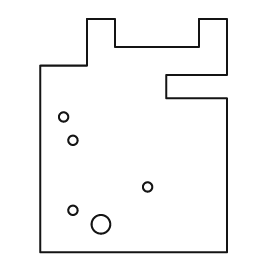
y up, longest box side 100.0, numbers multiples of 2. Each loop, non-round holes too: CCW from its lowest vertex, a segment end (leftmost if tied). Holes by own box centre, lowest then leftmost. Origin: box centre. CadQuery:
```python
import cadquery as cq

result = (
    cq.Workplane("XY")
    .moveTo(-40.0, -50.0)
    .lineTo(40.0, -50.0)
    .lineTo(40.0, 16.0)
    .lineTo(14.0, 16.0)
    .lineTo(14.0, 26.0)
    .lineTo(40.0, 26.0)
    .lineTo(40.0, 50.0)
    .lineTo(28.0, 50.0)
    .lineTo(28.0, 38.0)
    .lineTo(-8.0, 38.0)
    .lineTo(-8.0, 50.0)
    .lineTo(-20.0, 50.0)
    .lineTo(-20.0, 30.0)
    .lineTo(-40.0, 30.0)
    .close()
    .moveTo(-14.0, -38.0)
    .circle(4.0)
    .moveTo(-26.0, -32.0)
    .circle(2.0)
    .moveTo(6.0, -22.0)
    .circle(2.0)
    .moveTo(-26.0, -2.0)
    .circle(2.0)
    .moveTo(-30.0, 8.0)
    .circle(2.0)
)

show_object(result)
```